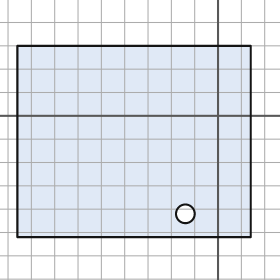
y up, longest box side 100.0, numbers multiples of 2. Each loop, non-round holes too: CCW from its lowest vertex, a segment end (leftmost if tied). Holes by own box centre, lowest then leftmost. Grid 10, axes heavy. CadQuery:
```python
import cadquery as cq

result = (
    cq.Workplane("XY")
    .moveTo(-86.0, -52.0)
    .lineTo(14.0, -52.0)
    .lineTo(14.0, 30.0)
    .lineTo(-86.0, 30.0)
    .close()
    .moveTo(-14.0, -42.0)
    .circle(4.0)
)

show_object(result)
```